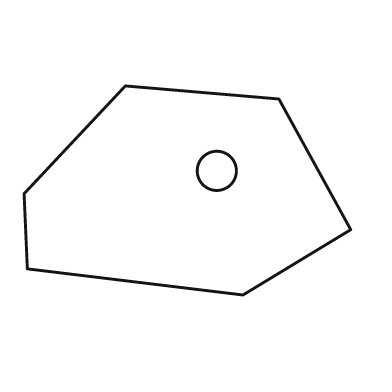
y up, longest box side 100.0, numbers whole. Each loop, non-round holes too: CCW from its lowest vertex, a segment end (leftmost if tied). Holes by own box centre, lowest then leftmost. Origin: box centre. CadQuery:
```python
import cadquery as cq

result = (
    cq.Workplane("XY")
    .moveTo(17.0, -32.0)
    .lineTo(50.0, -12.0)
    .lineTo(28.0, 28.0)
    .lineTo(-19.0, 32.0)
    .lineTo(-50.0, -1.0)
    .lineTo(-49.0, -24.0)
    .close()
    .moveTo(9.0, 6.0)
    .circle(6.0)
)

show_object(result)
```